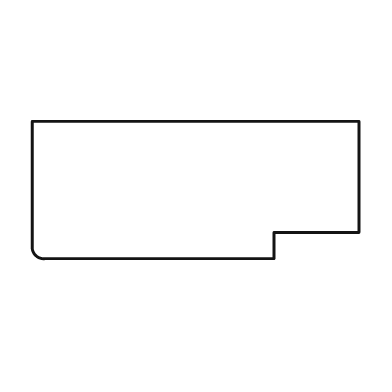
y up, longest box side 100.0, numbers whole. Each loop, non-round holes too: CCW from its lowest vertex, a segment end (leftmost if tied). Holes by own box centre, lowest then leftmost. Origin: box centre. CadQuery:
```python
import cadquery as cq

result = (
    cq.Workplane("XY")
    .moveTo(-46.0, -21.0)
    .lineTo(24.0, -21.0)
    .lineTo(24.0, -13.0)
    .lineTo(50.0, -13.0)
    .lineTo(50.0, 21.0)
    .lineTo(-50.0, 21.0)
    .lineTo(-50.0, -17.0)
    .threePointArc((-49.0, -20.0), (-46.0, -21.0))
    .close()
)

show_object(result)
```